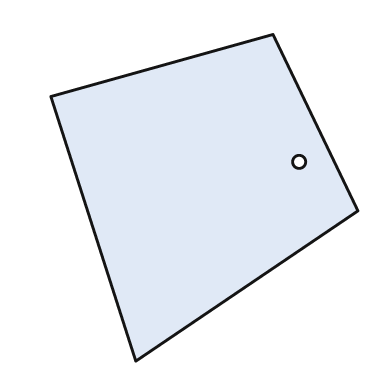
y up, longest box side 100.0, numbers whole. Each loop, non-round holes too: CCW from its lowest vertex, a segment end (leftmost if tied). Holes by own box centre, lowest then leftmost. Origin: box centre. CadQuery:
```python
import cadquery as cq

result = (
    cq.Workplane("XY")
    .moveTo(-21.0, -50.0)
    .lineTo(47.0, -4.0)
    .lineTo(21.0, 50.0)
    .lineTo(-47.0, 31.0)
    .close()
    .moveTo(29.0, 11.0)
    .circle(2.0)
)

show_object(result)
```